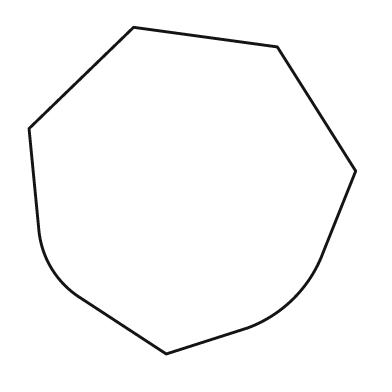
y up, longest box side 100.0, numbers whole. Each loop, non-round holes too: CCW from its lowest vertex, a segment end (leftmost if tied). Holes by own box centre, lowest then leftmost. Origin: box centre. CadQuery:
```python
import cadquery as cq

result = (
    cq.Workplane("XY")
    .moveTo(-8.0, -50.0)
    .lineTo(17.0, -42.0)
    .threePointArc((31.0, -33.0), (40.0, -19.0))
    .lineTo(50.0, 6.0)
    .lineTo(26.0, 44.0)
    .lineTo(-18.0, 50.0)
    .lineTo(-50.0, 19.0)
    .lineTo(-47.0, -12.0)
    .threePointArc((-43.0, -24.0), (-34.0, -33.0))
    .close()
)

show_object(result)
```